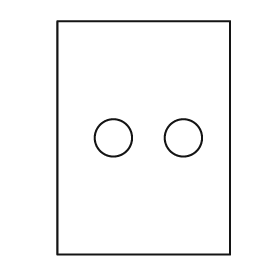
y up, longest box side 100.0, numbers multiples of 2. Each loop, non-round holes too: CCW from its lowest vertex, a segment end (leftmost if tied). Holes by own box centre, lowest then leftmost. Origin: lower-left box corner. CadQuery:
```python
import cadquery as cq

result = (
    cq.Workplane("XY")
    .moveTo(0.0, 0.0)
    .lineTo(74.0, 0.0)
    .lineTo(74.0, 100.0)
    .lineTo(0.0, 100.0)
    .close()
    .moveTo(24.0, 50.0)
    .circle(8.0)
    .moveTo(54.0, 50.0)
    .circle(8.0)
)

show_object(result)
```